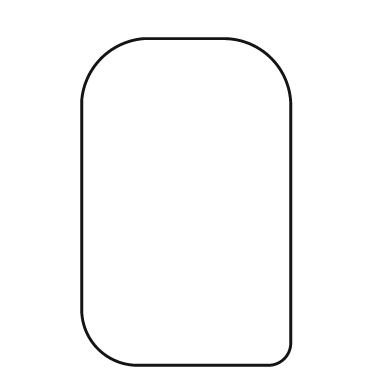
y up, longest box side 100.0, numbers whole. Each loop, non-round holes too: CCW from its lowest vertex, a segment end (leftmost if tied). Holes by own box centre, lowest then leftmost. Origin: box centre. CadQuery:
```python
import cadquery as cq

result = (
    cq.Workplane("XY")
    .moveTo(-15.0, -50.0)
    .lineTo(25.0, -50.0)
    .threePointArc((30.0, -48.0), (32.0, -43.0))
    .lineTo(32.0, 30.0)
    .threePointArc((26.0, 44.0), (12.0, 50.0))
    .lineTo(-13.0, 50.0)
    .threePointArc((-26.0, 44.0), (-32.0, 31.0))
    .lineTo(-32.0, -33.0)
    .threePointArc((-27.0, -45.0), (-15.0, -50.0))
    .close()
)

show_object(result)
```